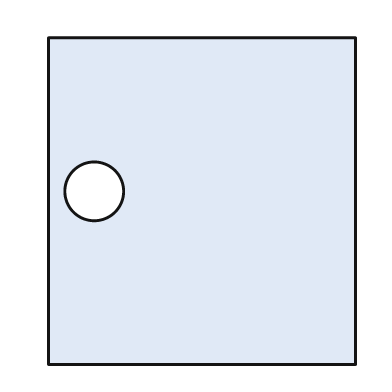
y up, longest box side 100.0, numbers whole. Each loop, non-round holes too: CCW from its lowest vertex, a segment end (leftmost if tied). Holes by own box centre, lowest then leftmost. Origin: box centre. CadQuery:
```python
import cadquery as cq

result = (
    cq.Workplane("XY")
    .moveTo(-47.0, -50.0)
    .lineTo(47.0, -50.0)
    .lineTo(47.0, 50.0)
    .lineTo(-47.0, 50.0)
    .close()
    .moveTo(-33.0, 3.0)
    .circle(9.0)
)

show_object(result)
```